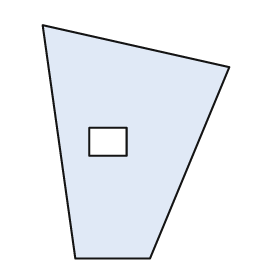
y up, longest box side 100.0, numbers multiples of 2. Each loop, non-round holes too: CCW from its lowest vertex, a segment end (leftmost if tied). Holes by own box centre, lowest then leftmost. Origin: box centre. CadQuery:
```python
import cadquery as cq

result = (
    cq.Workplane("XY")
    .moveTo(-26.0, -50.0)
    .lineTo(6.0, -50.0)
    .lineTo(40.0, 32.0)
    .lineTo(-40.0, 50.0)
    .close()
    .moveTo(-20.0, -6.0)
    .lineTo(-4.0, -6.0)
    .lineTo(-4.0, 6.0)
    .lineTo(-20.0, 6.0)
    .close()
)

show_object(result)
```